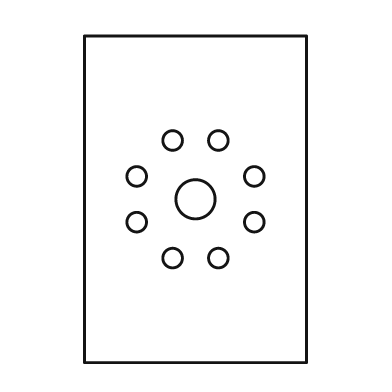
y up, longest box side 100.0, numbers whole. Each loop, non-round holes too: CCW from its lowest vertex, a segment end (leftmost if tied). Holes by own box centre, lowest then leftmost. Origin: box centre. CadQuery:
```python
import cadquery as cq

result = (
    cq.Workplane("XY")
    .moveTo(-34.0, -50.0)
    .lineTo(34.0, -50.0)
    .lineTo(34.0, 50.0)
    .lineTo(-34.0, 50.0)
    .close()
    .moveTo(-7.0, -18.0)
    .circle(3.0)
    .moveTo(7.0, -18.0)
    .circle(3.0)
    .moveTo(-18.0, -7.0)
    .circle(3.0)
    .moveTo(18.0, -7.0)
    .circle(3.0)
    .moveTo(0.0, 0.0)
    .circle(6.0)
    .moveTo(-18.0, 7.0)
    .circle(3.0)
    .moveTo(18.0, 7.0)
    .circle(3.0)
    .moveTo(-7.0, 18.0)
    .circle(3.0)
    .moveTo(7.0, 18.0)
    .circle(3.0)
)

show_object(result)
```